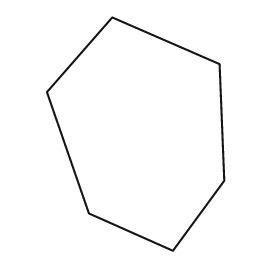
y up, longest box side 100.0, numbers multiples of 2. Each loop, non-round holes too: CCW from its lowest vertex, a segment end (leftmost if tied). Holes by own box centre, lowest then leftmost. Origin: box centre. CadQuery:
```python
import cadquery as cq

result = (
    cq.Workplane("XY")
    .moveTo(16.0, -50.0)
    .lineTo(38.0, -20.0)
    .lineTo(36.0, 30.0)
    .lineTo(-10.0, 50.0)
    .lineTo(-38.0, 18.0)
    .lineTo(-20.0, -34.0)
    .close()
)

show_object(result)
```